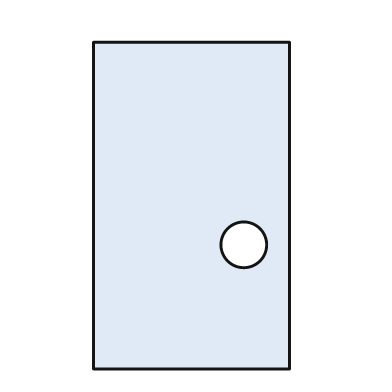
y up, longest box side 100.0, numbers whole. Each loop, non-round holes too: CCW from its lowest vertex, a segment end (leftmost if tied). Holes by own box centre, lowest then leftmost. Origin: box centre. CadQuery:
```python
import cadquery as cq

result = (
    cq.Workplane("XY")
    .moveTo(-30.0, -50.0)
    .lineTo(30.0, -50.0)
    .lineTo(30.0, 50.0)
    .lineTo(-30.0, 50.0)
    .close()
    .moveTo(16.0, -12.0)
    .circle(7.0)
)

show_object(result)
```